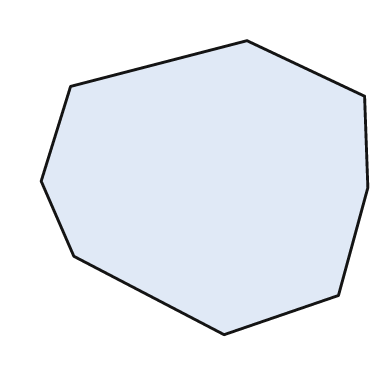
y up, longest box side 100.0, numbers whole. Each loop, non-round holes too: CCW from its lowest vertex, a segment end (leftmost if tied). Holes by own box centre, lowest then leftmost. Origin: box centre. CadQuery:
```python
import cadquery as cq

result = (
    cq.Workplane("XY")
    .moveTo(6.0, -45.0)
    .lineTo(41.0, -33.0)
    .lineTo(50.0, 0.0)
    .lineTo(49.0, 28.0)
    .lineTo(13.0, 45.0)
    .lineTo(-41.0, 31.0)
    .lineTo(-50.0, 2.0)
    .lineTo(-40.0, -21.0)
    .close()
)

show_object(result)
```